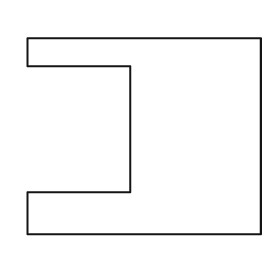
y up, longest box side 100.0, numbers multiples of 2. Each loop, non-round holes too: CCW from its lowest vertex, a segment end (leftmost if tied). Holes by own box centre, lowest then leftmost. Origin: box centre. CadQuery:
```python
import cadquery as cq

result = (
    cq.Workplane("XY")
    .moveTo(-50.0, -42.0)
    .lineTo(50.0, -42.0)
    .lineTo(50.0, 42.0)
    .lineTo(-50.0, 42.0)
    .lineTo(-50.0, 30.0)
    .lineTo(-6.0, 30.0)
    .lineTo(-6.0, -24.0)
    .lineTo(-50.0, -24.0)
    .close()
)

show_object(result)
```